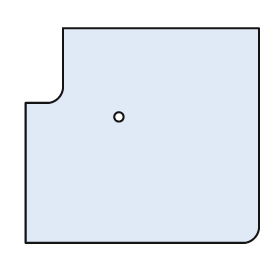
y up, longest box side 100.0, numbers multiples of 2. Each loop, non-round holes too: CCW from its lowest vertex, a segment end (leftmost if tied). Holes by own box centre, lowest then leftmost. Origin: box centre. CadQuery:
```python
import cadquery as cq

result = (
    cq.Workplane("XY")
    .moveTo(-50.0, -46.0)
    .lineTo(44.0, -46.0)
    .threePointArc((48.0, -44.0), (50.0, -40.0))
    .lineTo(50.0, 46.0)
    .lineTo(-34.0, 46.0)
    .lineTo(-34.0, 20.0)
    .threePointArc((-36.0, 16.0), (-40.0, 14.0))
    .lineTo(-50.0, 14.0)
    .close()
    .moveTo(-10.0, 8.0)
    .circle(2.0)
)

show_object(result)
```